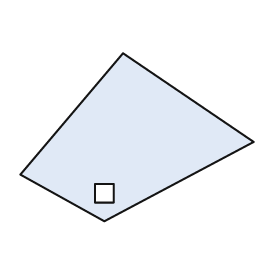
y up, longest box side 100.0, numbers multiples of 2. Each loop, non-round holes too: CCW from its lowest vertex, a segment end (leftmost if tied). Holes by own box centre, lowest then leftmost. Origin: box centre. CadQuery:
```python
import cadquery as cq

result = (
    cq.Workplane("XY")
    .moveTo(-14.0, -36.0)
    .lineTo(50.0, -2.0)
    .lineTo(-6.0, 36.0)
    .lineTo(-50.0, -16.0)
    .close()
    .moveTo(-18.0, -28.0)
    .lineTo(-10.0, -28.0)
    .lineTo(-10.0, -20.0)
    .lineTo(-18.0, -20.0)
    .close()
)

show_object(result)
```